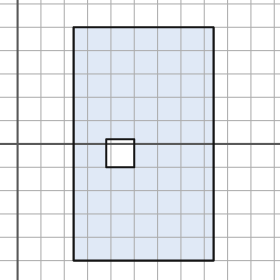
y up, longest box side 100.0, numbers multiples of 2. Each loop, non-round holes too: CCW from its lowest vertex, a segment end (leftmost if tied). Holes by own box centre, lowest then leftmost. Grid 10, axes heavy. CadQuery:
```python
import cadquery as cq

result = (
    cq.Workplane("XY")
    .moveTo(24.0, -50.0)
    .lineTo(84.0, -50.0)
    .lineTo(84.0, 50.0)
    .lineTo(24.0, 50.0)
    .close()
    .moveTo(38.0, -10.0)
    .lineTo(50.0, -10.0)
    .lineTo(50.0, 2.0)
    .lineTo(38.0, 2.0)
    .close()
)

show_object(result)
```